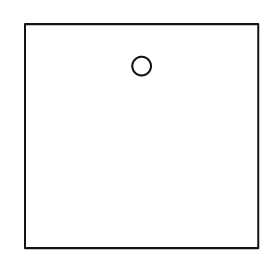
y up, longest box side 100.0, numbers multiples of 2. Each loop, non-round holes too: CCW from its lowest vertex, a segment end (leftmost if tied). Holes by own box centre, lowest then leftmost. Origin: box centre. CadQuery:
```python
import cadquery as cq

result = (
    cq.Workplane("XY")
    .moveTo(-50.0, -48.0)
    .lineTo(50.0, -48.0)
    .lineTo(50.0, 48.0)
    .lineTo(-50.0, 48.0)
    .close()
    .moveTo(0.0, 30.0)
    .circle(4.0)
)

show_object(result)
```